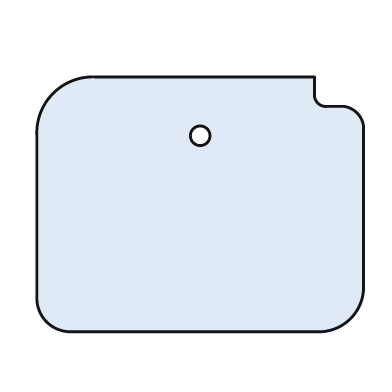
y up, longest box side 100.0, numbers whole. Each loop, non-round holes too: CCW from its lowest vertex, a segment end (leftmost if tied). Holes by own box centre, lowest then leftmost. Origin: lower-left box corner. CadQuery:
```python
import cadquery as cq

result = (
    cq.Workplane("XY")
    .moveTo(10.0, 0.0)
    .lineTo(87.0, 0.0)
    .threePointArc((96.0, 4.0), (100.0, 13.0))
    .lineTo(100.0, 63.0)
    .threePointArc((98.0, 67.0), (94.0, 69.0))
    .lineTo(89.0, 69.0)
    .threePointArc((86.0, 70.0), (85.0, 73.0))
    .lineTo(85.0, 78.0)
    .lineTo(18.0, 78.0)
    .threePointArc((5.0, 73.0), (0.0, 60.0))
    .lineTo(0.0, 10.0)
    .threePointArc((3.0, 3.0), (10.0, 0.0))
    .close()
    .moveTo(50.0, 60.0)
    .circle(3.0)
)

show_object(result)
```